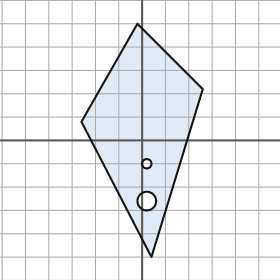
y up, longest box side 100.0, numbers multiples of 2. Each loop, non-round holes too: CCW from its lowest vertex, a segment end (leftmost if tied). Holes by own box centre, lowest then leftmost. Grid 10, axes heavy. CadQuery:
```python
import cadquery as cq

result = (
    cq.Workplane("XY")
    .moveTo(4.0, -50.0)
    .lineTo(26.0, 22.0)
    .lineTo(-2.0, 50.0)
    .lineTo(-26.0, 8.0)
    .close()
    .moveTo(2.0, -26.0)
    .circle(4.0)
    .moveTo(2.0, -10.0)
    .circle(2.0)
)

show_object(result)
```